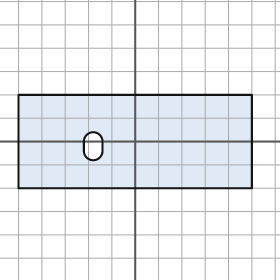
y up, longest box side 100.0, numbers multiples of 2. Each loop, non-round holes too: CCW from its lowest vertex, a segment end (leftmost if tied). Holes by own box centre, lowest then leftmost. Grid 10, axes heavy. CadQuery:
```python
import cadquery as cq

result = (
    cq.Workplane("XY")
    .moveTo(-50.0, -20.0)
    .lineTo(50.0, -20.0)
    .lineTo(50.0, 20.0)
    .lineTo(-50.0, 20.0)
    .close()
    .moveTo(-22.0, -4.0)
    .threePointArc((-18.0, -8.0), (-14.0, -4.0))
    .lineTo(-14.0, 0.0)
    .threePointArc((-18.0, 4.0), (-22.0, 0.0))
    .close()
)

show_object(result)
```